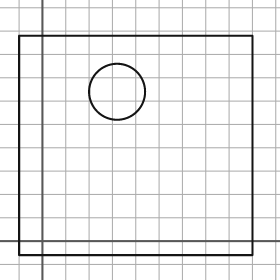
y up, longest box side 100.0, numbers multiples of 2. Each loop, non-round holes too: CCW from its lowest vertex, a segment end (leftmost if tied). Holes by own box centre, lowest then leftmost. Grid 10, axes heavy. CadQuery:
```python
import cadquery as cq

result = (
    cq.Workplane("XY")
    .moveTo(-10.0, -6.0)
    .lineTo(90.0, -6.0)
    .lineTo(90.0, 88.0)
    .lineTo(-10.0, 88.0)
    .close()
    .moveTo(32.0, 64.0)
    .circle(12.0)
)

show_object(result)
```